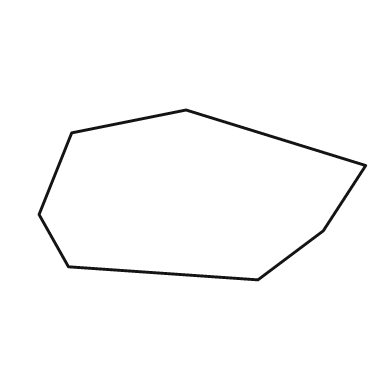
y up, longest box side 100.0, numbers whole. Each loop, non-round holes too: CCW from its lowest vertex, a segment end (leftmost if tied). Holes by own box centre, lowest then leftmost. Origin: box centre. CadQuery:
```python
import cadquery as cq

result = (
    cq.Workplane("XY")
    .moveTo(17.0, -26.0)
    .lineTo(37.0, -11.0)
    .lineTo(50.0, 9.0)
    .lineTo(-5.0, 26.0)
    .lineTo(-40.0, 19.0)
    .lineTo(-50.0, -6.0)
    .lineTo(-41.0, -22.0)
    .close()
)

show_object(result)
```